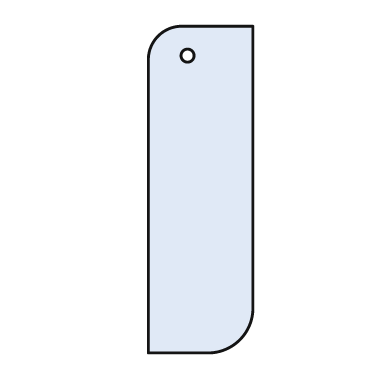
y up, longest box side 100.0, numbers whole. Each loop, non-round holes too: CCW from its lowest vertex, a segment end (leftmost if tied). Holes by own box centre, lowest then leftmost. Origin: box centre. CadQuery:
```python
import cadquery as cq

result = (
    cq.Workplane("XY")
    .moveTo(-16.0, -50.0)
    .lineTo(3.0, -50.0)
    .threePointArc((12.0, -46.0), (16.0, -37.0))
    .lineTo(16.0, 50.0)
    .lineTo(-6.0, 50.0)
    .threePointArc((-13.0, 47.0), (-16.0, 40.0))
    .close()
    .moveTo(-4.0, 41.0)
    .circle(2.0)
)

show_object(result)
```